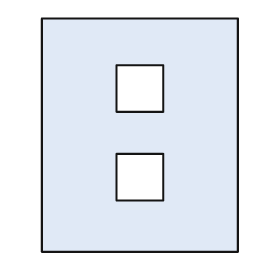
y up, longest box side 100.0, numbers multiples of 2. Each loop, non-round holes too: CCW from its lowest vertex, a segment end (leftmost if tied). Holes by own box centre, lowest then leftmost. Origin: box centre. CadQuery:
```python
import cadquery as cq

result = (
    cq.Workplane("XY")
    .moveTo(-42.0, -50.0)
    .lineTo(42.0, -50.0)
    .lineTo(42.0, 50.0)
    .lineTo(-42.0, 50.0)
    .close()
    .moveTo(-10.0, -28.0)
    .lineTo(10.0, -28.0)
    .lineTo(10.0, -8.0)
    .lineTo(-10.0, -8.0)
    .close()
    .moveTo(-10.0, 10.0)
    .lineTo(10.0, 10.0)
    .lineTo(10.0, 30.0)
    .lineTo(-10.0, 30.0)
    .close()
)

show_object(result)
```